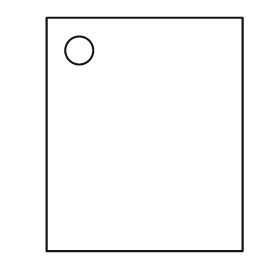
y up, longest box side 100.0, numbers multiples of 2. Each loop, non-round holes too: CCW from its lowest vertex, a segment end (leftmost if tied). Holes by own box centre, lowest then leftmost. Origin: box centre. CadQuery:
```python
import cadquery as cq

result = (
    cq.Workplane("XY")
    .moveTo(-42.0, -50.0)
    .lineTo(42.0, -50.0)
    .lineTo(42.0, 50.0)
    .lineTo(-42.0, 50.0)
    .close()
    .moveTo(-28.0, 36.0)
    .circle(6.0)
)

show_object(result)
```